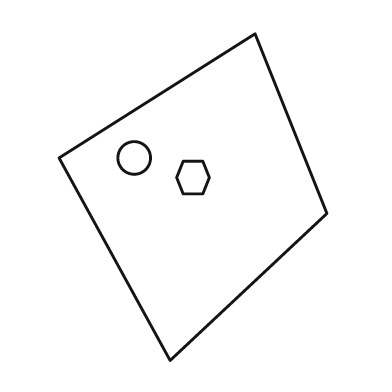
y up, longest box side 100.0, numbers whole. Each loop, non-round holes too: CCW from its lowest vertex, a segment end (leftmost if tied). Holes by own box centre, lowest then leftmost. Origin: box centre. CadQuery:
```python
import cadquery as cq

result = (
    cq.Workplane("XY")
    .moveTo(-7.0, -50.0)
    .lineTo(41.0, -5.0)
    .lineTo(19.0, 50.0)
    .lineTo(-41.0, 12.0)
    .close()
    .moveTo(-3.0, 1.0)
    .lineTo(3.0, 1.0)
    .lineTo(5.0, 6.0)
    .lineTo(3.0, 11.0)
    .lineTo(-3.0, 11.0)
    .lineTo(-5.0, 6.0)
    .close()
    .moveTo(-18.0, 12.0)
    .circle(5.0)
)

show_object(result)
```